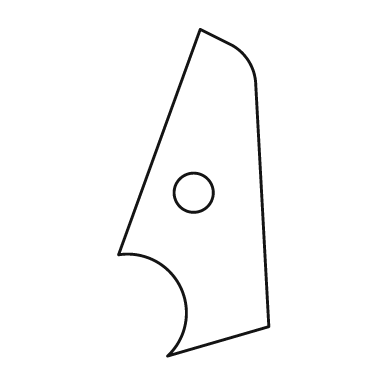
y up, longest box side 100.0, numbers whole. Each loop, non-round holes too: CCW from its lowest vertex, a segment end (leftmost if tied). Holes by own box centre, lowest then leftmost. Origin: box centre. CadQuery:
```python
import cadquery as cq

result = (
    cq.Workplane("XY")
    .moveTo(-8.0, -50.0)
    .lineTo(23.0, -41.0)
    .lineTo(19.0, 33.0)
    .threePointArc((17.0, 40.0), (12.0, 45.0))
    .lineTo(2.0, 50.0)
    .lineTo(-23.0, -19.0)
    .threePointArc((-4.0, -29.0), (-8.0, -50.0))
    .close()
    .moveTo(0.0, 0.0)
    .circle(6.0)
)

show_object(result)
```